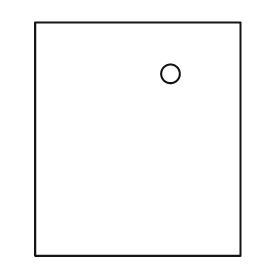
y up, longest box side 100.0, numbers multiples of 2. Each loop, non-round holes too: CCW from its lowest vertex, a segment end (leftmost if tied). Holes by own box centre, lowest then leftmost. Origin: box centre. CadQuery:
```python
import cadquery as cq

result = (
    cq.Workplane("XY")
    .moveTo(-44.0, -50.0)
    .lineTo(44.0, -50.0)
    .lineTo(44.0, 50.0)
    .lineTo(-44.0, 50.0)
    .close()
    .moveTo(14.0, 28.0)
    .circle(4.0)
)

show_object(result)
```